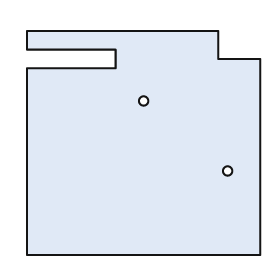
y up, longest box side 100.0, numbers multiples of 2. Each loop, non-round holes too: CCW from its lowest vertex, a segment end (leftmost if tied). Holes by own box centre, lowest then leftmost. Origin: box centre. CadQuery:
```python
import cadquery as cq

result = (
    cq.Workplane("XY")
    .moveTo(-50.0, -48.0)
    .lineTo(50.0, -48.0)
    .lineTo(50.0, 36.0)
    .lineTo(32.0, 36.0)
    .lineTo(32.0, 48.0)
    .lineTo(-50.0, 48.0)
    .lineTo(-50.0, 40.0)
    .lineTo(-12.0, 40.0)
    .lineTo(-12.0, 32.0)
    .lineTo(-50.0, 32.0)
    .close()
    .moveTo(36.0, -12.0)
    .circle(2.0)
    .moveTo(0.0, 18.0)
    .circle(2.0)
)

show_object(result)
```